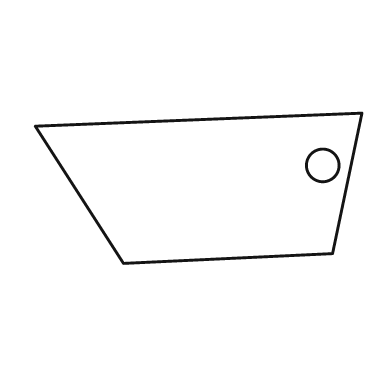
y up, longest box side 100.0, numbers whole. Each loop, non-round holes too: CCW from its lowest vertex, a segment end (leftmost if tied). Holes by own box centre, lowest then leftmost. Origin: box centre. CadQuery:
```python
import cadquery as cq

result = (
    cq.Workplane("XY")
    .moveTo(-23.0, -23.0)
    .lineTo(41.0, -20.0)
    .lineTo(50.0, 23.0)
    .lineTo(-50.0, 19.0)
    .close()
    .moveTo(38.0, 7.0)
    .circle(5.0)
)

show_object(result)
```